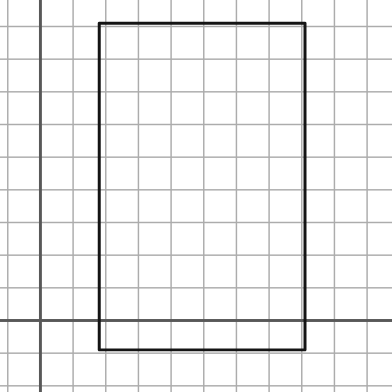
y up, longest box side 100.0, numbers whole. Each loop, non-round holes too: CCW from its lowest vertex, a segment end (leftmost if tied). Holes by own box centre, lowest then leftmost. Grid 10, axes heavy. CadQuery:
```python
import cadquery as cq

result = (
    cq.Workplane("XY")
    .moveTo(18.0, -9.0)
    .lineTo(81.0, -9.0)
    .lineTo(81.0, 91.0)
    .lineTo(18.0, 91.0)
    .close()
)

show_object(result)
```